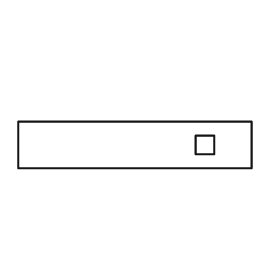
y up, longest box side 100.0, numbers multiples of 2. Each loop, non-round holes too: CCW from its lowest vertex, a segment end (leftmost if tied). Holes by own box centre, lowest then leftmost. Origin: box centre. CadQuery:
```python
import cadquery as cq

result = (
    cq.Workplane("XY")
    .moveTo(-50.0, -10.0)
    .lineTo(50.0, -10.0)
    .lineTo(50.0, 10.0)
    .lineTo(-50.0, 10.0)
    .close()
    .moveTo(26.0, -4.0)
    .lineTo(34.0, -4.0)
    .lineTo(34.0, 4.0)
    .lineTo(26.0, 4.0)
    .close()
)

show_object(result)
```